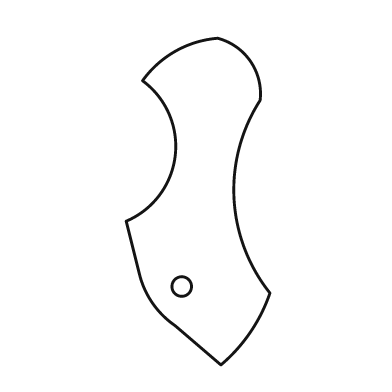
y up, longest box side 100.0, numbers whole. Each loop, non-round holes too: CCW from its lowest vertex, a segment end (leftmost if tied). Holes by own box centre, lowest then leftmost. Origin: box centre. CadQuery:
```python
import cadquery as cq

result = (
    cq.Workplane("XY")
    .moveTo(7.0, -50.0)
    .threePointArc((16.0, -40.0), (22.0, -28.0))
    .threePointArc((11.0, 1.0), (19.0, 31.0))
    .threePointArc((16.0, 43.0), (6.0, 50.0))
    .threePointArc((-7.0, 46.0), (-17.0, 37.0))
    .threePointArc((-7.0, 14.0), (-22.0, -6.0))
    .lineTo(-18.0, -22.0)
    .threePointArc((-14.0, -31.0), (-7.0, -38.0))
    .close()
    .moveTo(-5.0, -26.0)
    .circle(3.0)
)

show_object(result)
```